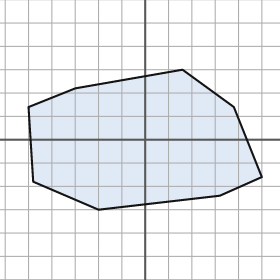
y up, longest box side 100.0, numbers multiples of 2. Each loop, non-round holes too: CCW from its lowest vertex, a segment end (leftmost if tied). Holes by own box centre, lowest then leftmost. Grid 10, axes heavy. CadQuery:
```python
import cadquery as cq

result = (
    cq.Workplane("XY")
    .moveTo(-20.0, -30.0)
    .lineTo(32.0, -24.0)
    .lineTo(50.0, -16.0)
    .lineTo(38.0, 14.0)
    .lineTo(16.0, 30.0)
    .lineTo(-30.0, 22.0)
    .lineTo(-50.0, 14.0)
    .lineTo(-48.0, -18.0)
    .close()
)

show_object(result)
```